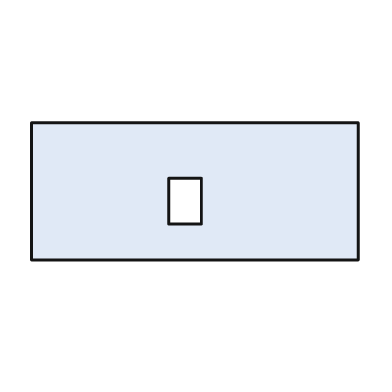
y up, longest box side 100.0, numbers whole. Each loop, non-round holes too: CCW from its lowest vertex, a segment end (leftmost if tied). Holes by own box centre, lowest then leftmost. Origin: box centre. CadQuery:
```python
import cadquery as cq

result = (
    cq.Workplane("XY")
    .moveTo(-50.0, -21.0)
    .lineTo(50.0, -21.0)
    .lineTo(50.0, 21.0)
    .lineTo(-50.0, 21.0)
    .close()
    .moveTo(-8.0, -10.0)
    .lineTo(2.0, -10.0)
    .lineTo(2.0, 4.0)
    .lineTo(-8.0, 4.0)
    .close()
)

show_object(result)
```